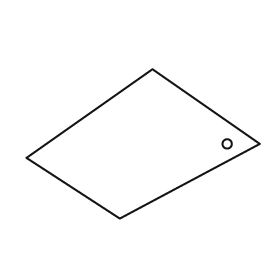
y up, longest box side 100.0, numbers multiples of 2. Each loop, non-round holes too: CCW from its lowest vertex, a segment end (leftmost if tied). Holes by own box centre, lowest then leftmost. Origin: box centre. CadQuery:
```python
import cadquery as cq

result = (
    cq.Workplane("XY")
    .moveTo(-10.0, -32.0)
    .lineTo(50.0, 0.0)
    .lineTo(4.0, 32.0)
    .lineTo(-50.0, -6.0)
    .close()
    .moveTo(36.0, 0.0)
    .circle(2.0)
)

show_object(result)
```